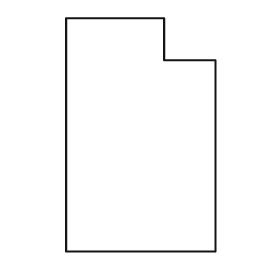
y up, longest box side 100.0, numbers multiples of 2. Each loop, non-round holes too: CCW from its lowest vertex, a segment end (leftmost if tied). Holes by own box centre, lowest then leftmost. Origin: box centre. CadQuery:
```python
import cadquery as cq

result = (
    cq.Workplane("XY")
    .moveTo(-32.0, -50.0)
    .lineTo(32.0, -50.0)
    .lineTo(32.0, 32.0)
    .lineTo(10.0, 32.0)
    .lineTo(10.0, 50.0)
    .lineTo(-32.0, 50.0)
    .close()
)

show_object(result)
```